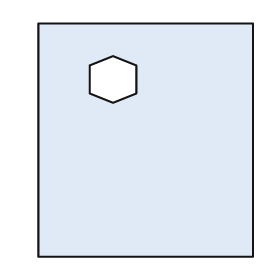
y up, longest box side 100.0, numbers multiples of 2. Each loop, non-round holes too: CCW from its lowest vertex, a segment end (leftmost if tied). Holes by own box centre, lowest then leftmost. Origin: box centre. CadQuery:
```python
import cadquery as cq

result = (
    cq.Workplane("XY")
    .moveTo(-46.0, -50.0)
    .lineTo(46.0, -50.0)
    .lineTo(46.0, 50.0)
    .lineTo(-46.0, 50.0)
    .close()
    .moveTo(-14.0, 16.0)
    .lineTo(-4.0, 20.0)
    .lineTo(-4.0, 32.0)
    .lineTo(-14.0, 36.0)
    .lineTo(-24.0, 32.0)
    .lineTo(-24.0, 20.0)
    .close()
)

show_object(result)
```